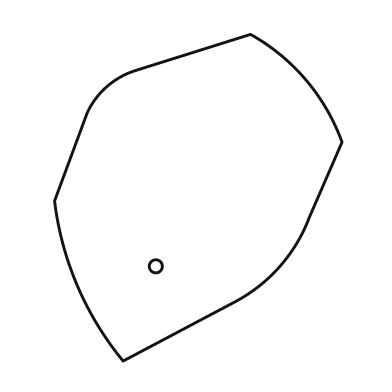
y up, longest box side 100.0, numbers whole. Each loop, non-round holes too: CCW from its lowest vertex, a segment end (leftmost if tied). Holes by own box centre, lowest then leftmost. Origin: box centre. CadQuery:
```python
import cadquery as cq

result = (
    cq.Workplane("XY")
    .moveTo(-23.0, -50.0)
    .lineTo(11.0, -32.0)
    .threePointArc((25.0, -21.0), (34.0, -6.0))
    .lineTo(44.0, 17.0)
    .threePointArc((33.0, 36.0), (16.0, 50.0))
    .lineTo(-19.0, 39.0)
    .threePointArc((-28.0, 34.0), (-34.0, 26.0))
    .lineTo(-44.0, -1.0)
    .threePointArc((-37.0, -27.0), (-23.0, -50.0))
    .close()
    .moveTo(-13.0, -21.0)
    .circle(2.0)
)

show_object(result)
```